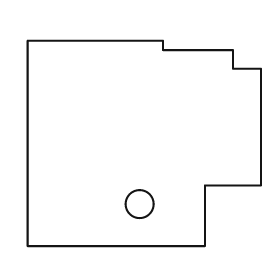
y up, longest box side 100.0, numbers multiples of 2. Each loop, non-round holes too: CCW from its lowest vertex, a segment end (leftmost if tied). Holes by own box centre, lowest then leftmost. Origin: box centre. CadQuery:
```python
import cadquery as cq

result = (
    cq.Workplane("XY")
    .moveTo(-50.0, -44.0)
    .lineTo(26.0, -44.0)
    .lineTo(26.0, -18.0)
    .lineTo(50.0, -18.0)
    .lineTo(50.0, 32.0)
    .lineTo(38.0, 32.0)
    .lineTo(38.0, 40.0)
    .lineTo(8.0, 40.0)
    .lineTo(8.0, 44.0)
    .lineTo(-50.0, 44.0)
    .close()
    .moveTo(-2.0, -26.0)
    .circle(6.0)
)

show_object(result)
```